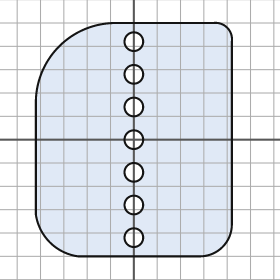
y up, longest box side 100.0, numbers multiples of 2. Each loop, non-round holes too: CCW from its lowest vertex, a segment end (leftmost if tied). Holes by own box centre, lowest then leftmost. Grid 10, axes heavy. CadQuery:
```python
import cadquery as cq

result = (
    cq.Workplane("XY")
    .moveTo(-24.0, -50.0)
    .lineTo(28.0, -50.0)
    .threePointArc((38.0, -46.0), (42.0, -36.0))
    .lineTo(42.0, 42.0)
    .threePointArc((40.0, 48.0), (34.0, 50.0))
    .lineTo(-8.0, 50.0)
    .threePointArc((-32.0, 40.0), (-42.0, 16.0))
    .lineTo(-42.0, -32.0)
    .threePointArc((-36.0, -44.0), (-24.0, -50.0))
    .close()
    .moveTo(0.0, -42.0)
    .circle(4.0)
    .moveTo(0.0, -28.0)
    .circle(4.0)
    .moveTo(0.0, -14.0)
    .circle(4.0)
    .moveTo(0.0, 0.0)
    .circle(4.0)
    .moveTo(0.0, 14.0)
    .circle(4.0)
    .moveTo(0.0, 28.0)
    .circle(4.0)
    .moveTo(0.0, 42.0)
    .circle(4.0)
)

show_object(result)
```